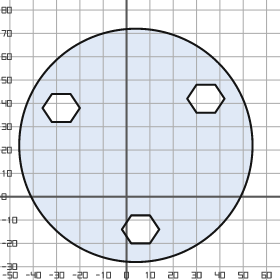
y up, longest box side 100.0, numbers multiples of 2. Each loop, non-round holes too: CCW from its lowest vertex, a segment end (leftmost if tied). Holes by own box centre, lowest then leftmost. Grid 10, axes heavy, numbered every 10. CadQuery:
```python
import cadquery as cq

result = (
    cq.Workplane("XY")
    .moveTo(4.0, 22.0)
    .circle(50.0)
    .moveTo(2.0, -20.0)
    .lineTo(10.0, -20.0)
    .lineTo(14.0, -14.0)
    .lineTo(10.0, -8.0)
    .lineTo(2.0, -8.0)
    .lineTo(-2.0, -14.0)
    .close()
    .moveTo(-32.0, 32.0)
    .lineTo(-24.0, 32.0)
    .lineTo(-20.0, 38.0)
    .lineTo(-24.0, 44.0)
    .lineTo(-32.0, 44.0)
    .lineTo(-36.0, 38.0)
    .close()
    .moveTo(30.0, 36.0)
    .lineTo(38.0, 36.0)
    .lineTo(42.0, 42.0)
    .lineTo(38.0, 48.0)
    .lineTo(30.0, 48.0)
    .lineTo(26.0, 42.0)
    .close()
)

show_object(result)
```